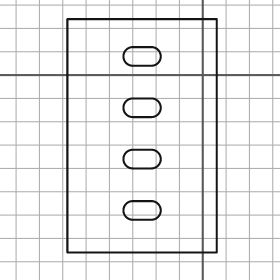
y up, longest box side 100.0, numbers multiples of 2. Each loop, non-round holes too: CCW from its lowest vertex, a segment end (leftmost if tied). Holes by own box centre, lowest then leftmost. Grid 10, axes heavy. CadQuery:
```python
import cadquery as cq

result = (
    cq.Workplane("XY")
    .moveTo(-58.0, -76.0)
    .lineTo(6.0, -76.0)
    .lineTo(6.0, 24.0)
    .lineTo(-58.0, 24.0)
    .close()
    .moveTo(-30.0, -62.0)
    .lineTo(-22.0, -62.0)
    .threePointArc((-18.0, -58.0), (-22.0, -54.0))
    .lineTo(-30.0, -54.0)
    .threePointArc((-34.0, -58.0), (-30.0, -62.0))
    .close()
    .moveTo(-30.0, -40.0)
    .lineTo(-22.0, -40.0)
    .threePointArc((-18.0, -36.0), (-22.0, -32.0))
    .lineTo(-30.0, -32.0)
    .threePointArc((-34.0, -36.0), (-30.0, -40.0))
    .close()
    .moveTo(-30.0, -18.0)
    .lineTo(-22.0, -18.0)
    .threePointArc((-18.0, -14.0), (-22.0, -10.0))
    .lineTo(-30.0, -10.0)
    .threePointArc((-34.0, -14.0), (-30.0, -18.0))
    .close()
    .moveTo(-30.0, 4.0)
    .lineTo(-22.0, 4.0)
    .threePointArc((-18.0, 8.0), (-22.0, 12.0))
    .lineTo(-30.0, 12.0)
    .threePointArc((-34.0, 8.0), (-30.0, 4.0))
    .close()
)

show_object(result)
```